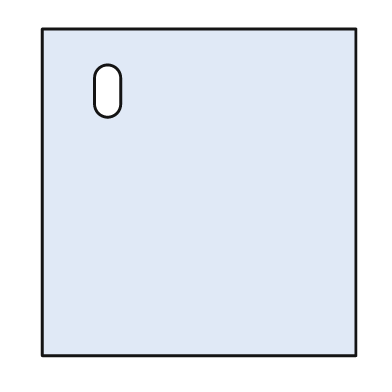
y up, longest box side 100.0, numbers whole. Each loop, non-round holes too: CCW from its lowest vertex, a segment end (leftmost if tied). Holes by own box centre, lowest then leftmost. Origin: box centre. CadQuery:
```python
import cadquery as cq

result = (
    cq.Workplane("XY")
    .moveTo(-48.0, -50.0)
    .lineTo(48.0, -50.0)
    .lineTo(48.0, 50.0)
    .lineTo(-48.0, 50.0)
    .close()
    .moveTo(-32.0, 27.0)
    .threePointArc((-28.0, 23.0), (-24.0, 27.0))
    .lineTo(-24.0, 35.0)
    .threePointArc((-28.0, 39.0), (-32.0, 35.0))
    .close()
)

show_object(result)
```